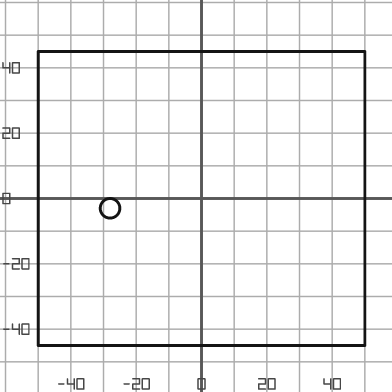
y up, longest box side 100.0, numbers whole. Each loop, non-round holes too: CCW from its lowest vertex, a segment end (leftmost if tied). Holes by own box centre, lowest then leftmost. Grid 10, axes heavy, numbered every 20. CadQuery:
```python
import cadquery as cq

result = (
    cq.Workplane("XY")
    .moveTo(-50.0, -45.0)
    .lineTo(50.0, -45.0)
    .lineTo(50.0, 45.0)
    .lineTo(-50.0, 45.0)
    .close()
    .moveTo(-28.0, -3.0)
    .circle(3.0)
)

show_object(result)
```